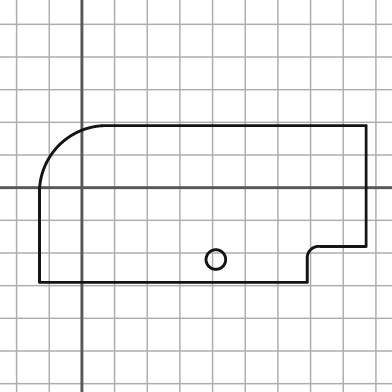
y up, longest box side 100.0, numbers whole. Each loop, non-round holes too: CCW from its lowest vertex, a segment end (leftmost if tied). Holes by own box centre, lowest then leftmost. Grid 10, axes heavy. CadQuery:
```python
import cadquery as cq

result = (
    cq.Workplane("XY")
    .moveTo(-13.0, -29.0)
    .lineTo(69.0, -29.0)
    .lineTo(69.0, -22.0)
    .threePointArc((70.0, -19.0), (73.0, -18.0))
    .lineTo(87.0, -18.0)
    .lineTo(87.0, 19.0)
    .lineTo(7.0, 19.0)
    .threePointArc((-7.0, 13.0), (-13.0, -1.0))
    .close()
    .moveTo(41.0, -22.0)
    .circle(3.0)
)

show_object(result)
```